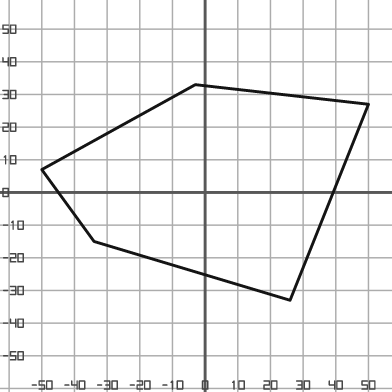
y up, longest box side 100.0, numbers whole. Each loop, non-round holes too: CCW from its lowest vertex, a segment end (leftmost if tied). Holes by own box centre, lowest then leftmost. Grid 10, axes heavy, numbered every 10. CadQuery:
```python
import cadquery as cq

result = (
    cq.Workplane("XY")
    .moveTo(26.0, -33.0)
    .lineTo(50.0, 27.0)
    .lineTo(-3.0, 33.0)
    .lineTo(-50.0, 7.0)
    .lineTo(-34.0, -15.0)
    .close()
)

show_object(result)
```